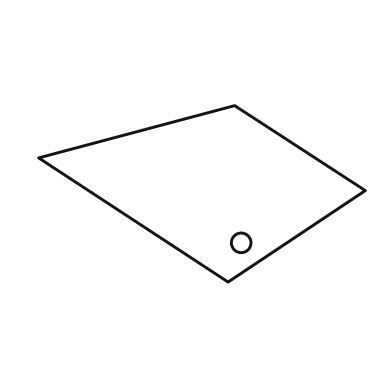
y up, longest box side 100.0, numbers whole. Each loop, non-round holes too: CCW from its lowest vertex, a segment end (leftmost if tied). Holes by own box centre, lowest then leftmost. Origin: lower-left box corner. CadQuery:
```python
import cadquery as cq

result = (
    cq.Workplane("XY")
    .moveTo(58.0, 0.0)
    .lineTo(100.0, 28.0)
    .lineTo(60.0, 54.0)
    .lineTo(0.0, 38.0)
    .close()
    .moveTo(62.0, 12.0)
    .circle(3.0)
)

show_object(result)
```